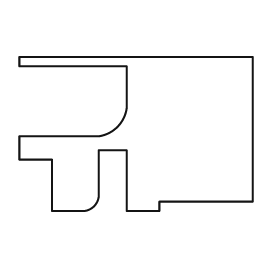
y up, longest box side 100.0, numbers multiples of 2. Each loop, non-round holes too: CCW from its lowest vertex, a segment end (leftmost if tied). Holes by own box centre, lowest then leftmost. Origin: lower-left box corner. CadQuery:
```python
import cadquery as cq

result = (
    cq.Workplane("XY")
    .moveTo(14.0, 0.0)
    .lineTo(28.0, 0.0)
    .threePointArc((32.0, 2.0), (34.0, 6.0))
    .lineTo(34.0, 26.0)
    .lineTo(46.0, 26.0)
    .lineTo(46.0, 0.0)
    .lineTo(60.0, 0.0)
    .lineTo(60.0, 4.0)
    .lineTo(100.0, 4.0)
    .lineTo(100.0, 66.0)
    .lineTo(0.0, 66.0)
    .lineTo(0.0, 62.0)
    .lineTo(46.0, 62.0)
    .lineTo(46.0, 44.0)
    .threePointArc((42.0, 36.0), (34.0, 32.0))
    .lineTo(0.0, 32.0)
    .lineTo(0.0, 22.0)
    .lineTo(14.0, 22.0)
    .close()
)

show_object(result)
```